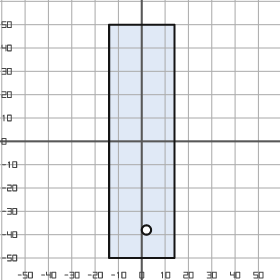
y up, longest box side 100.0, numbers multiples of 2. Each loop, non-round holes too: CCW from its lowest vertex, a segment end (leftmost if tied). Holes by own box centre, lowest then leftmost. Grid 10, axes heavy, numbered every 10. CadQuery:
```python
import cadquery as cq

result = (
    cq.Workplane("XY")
    .moveTo(-14.0, -50.0)
    .lineTo(14.0, -50.0)
    .lineTo(14.0, 50.0)
    .lineTo(-14.0, 50.0)
    .close()
    .moveTo(2.0, -38.0)
    .circle(2.0)
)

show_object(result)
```